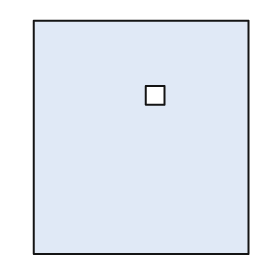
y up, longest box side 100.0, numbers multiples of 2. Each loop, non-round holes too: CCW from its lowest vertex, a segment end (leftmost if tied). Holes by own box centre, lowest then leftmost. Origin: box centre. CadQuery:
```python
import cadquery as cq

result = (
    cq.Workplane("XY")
    .moveTo(-46.0, -50.0)
    .lineTo(46.0, -50.0)
    .lineTo(46.0, 50.0)
    .lineTo(-46.0, 50.0)
    .close()
    .moveTo(2.0, 14.0)
    .lineTo(10.0, 14.0)
    .lineTo(10.0, 22.0)
    .lineTo(2.0, 22.0)
    .close()
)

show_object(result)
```